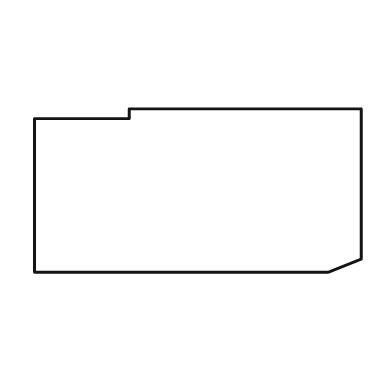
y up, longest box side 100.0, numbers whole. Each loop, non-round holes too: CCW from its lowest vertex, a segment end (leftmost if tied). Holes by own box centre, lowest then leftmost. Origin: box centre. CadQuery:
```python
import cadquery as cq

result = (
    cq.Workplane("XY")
    .moveTo(-50.0, -25.0)
    .lineTo(40.0, -25.0)
    .lineTo(50.0, -21.0)
    .lineTo(50.0, 25.0)
    .lineTo(-21.0, 25.0)
    .lineTo(-21.0, 22.0)
    .lineTo(-50.0, 22.0)
    .close()
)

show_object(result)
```